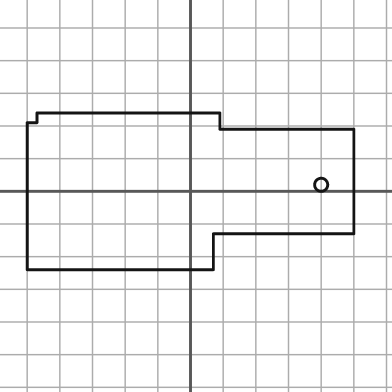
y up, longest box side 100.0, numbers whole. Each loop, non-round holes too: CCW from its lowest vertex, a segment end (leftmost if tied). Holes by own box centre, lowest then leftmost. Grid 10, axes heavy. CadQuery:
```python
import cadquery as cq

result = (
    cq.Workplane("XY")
    .moveTo(-50.0, -24.0)
    .lineTo(7.0, -24.0)
    .lineTo(7.0, -13.0)
    .lineTo(50.0, -13.0)
    .lineTo(50.0, 19.0)
    .lineTo(9.0, 19.0)
    .lineTo(9.0, 24.0)
    .lineTo(-47.0, 24.0)
    .lineTo(-47.0, 21.0)
    .lineTo(-50.0, 21.0)
    .close()
    .moveTo(40.0, 2.0)
    .circle(2.0)
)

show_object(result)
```